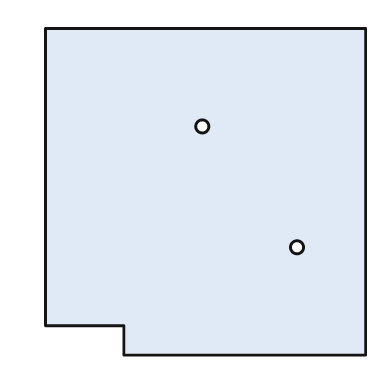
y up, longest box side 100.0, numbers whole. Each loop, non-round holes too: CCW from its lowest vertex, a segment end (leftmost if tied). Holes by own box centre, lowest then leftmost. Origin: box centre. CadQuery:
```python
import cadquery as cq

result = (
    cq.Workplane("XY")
    .moveTo(-25.0, -50.0)
    .lineTo(49.0, -50.0)
    .lineTo(49.0, 50.0)
    .lineTo(-49.0, 50.0)
    .lineTo(-49.0, -41.0)
    .lineTo(-25.0, -41.0)
    .close()
    .moveTo(28.0, -17.0)
    .circle(2.0)
    .moveTo(-1.0, 20.0)
    .circle(2.0)
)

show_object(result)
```